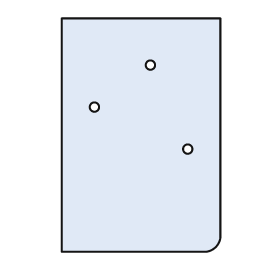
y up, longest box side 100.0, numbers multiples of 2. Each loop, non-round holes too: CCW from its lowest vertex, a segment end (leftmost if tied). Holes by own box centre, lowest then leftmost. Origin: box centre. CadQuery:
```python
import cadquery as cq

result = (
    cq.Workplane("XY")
    .moveTo(-34.0, -50.0)
    .lineTo(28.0, -50.0)
    .threePointArc((32.0, -48.0), (34.0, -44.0))
    .lineTo(34.0, 50.0)
    .lineTo(-34.0, 50.0)
    .close()
    .moveTo(20.0, -6.0)
    .circle(2.0)
    .moveTo(-20.0, 12.0)
    .circle(2.0)
    .moveTo(4.0, 30.0)
    .circle(2.0)
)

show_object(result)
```